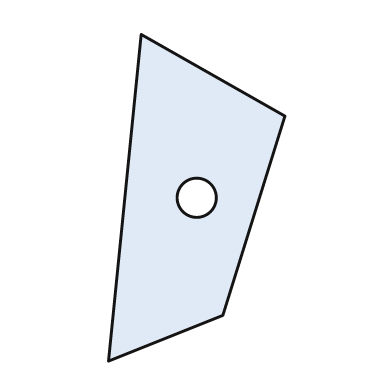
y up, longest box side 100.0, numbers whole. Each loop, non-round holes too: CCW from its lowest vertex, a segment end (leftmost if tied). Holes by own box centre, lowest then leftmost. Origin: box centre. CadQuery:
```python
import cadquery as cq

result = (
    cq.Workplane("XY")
    .moveTo(-27.0, -50.0)
    .lineTo(8.0, -36.0)
    .lineTo(27.0, 25.0)
    .lineTo(-17.0, 50.0)
    .close()
    .moveTo(0.0, 0.0)
    .circle(6.0)
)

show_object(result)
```